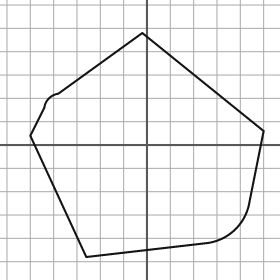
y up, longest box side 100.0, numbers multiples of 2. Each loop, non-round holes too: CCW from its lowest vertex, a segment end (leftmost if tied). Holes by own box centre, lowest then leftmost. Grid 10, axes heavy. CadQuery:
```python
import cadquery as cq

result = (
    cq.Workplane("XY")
    .moveTo(-26.0, -48.0)
    .lineTo(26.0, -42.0)
    .threePointArc((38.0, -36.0), (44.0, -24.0))
    .lineTo(50.0, 6.0)
    .lineTo(-2.0, 48.0)
    .lineTo(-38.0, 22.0)
    .threePointArc((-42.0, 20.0), (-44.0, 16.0))
    .lineTo(-50.0, 4.0)
    .close()
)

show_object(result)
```